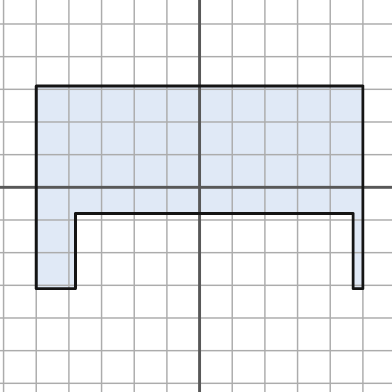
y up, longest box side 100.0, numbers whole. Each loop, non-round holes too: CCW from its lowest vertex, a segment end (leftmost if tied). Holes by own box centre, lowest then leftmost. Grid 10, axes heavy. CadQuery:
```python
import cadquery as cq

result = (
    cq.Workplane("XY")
    .moveTo(-50.0, -31.0)
    .lineTo(-38.0, -31.0)
    .lineTo(-38.0, -8.0)
    .lineTo(47.0, -8.0)
    .lineTo(47.0, -31.0)
    .lineTo(50.0, -31.0)
    .lineTo(50.0, 31.0)
    .lineTo(-50.0, 31.0)
    .close()
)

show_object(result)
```